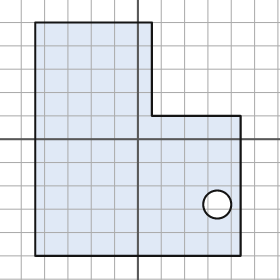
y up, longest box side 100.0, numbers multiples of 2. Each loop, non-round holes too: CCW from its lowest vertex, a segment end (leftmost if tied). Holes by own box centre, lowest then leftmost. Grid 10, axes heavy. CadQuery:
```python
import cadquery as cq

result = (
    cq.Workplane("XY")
    .moveTo(-44.0, -50.0)
    .lineTo(44.0, -50.0)
    .lineTo(44.0, 10.0)
    .lineTo(6.0, 10.0)
    .lineTo(6.0, 50.0)
    .lineTo(-44.0, 50.0)
    .close()
    .moveTo(34.0, -28.0)
    .circle(6.0)
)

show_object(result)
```